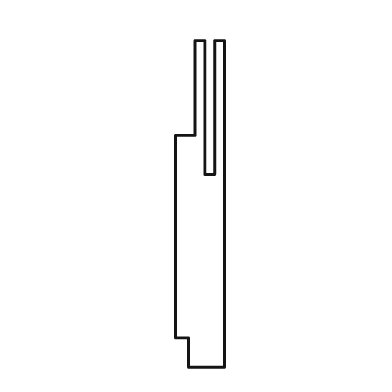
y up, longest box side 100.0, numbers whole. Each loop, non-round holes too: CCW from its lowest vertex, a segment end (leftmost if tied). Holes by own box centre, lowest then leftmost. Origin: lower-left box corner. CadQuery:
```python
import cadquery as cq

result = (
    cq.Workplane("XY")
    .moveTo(4.0, 0.0)
    .lineTo(15.0, 0.0)
    .lineTo(15.0, 100.0)
    .lineTo(12.0, 100.0)
    .lineTo(12.0, 59.0)
    .lineTo(9.0, 59.0)
    .lineTo(9.0, 100.0)
    .lineTo(6.0, 100.0)
    .lineTo(6.0, 71.0)
    .lineTo(0.0, 71.0)
    .lineTo(0.0, 9.0)
    .lineTo(4.0, 9.0)
    .close()
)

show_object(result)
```